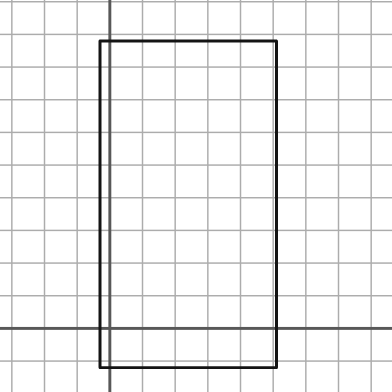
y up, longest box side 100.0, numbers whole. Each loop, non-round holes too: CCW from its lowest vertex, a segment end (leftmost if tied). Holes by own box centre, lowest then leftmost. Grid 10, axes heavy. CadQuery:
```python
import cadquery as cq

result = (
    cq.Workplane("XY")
    .moveTo(-3.0, -12.0)
    .lineTo(51.0, -12.0)
    .lineTo(51.0, 88.0)
    .lineTo(-3.0, 88.0)
    .close()
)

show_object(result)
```